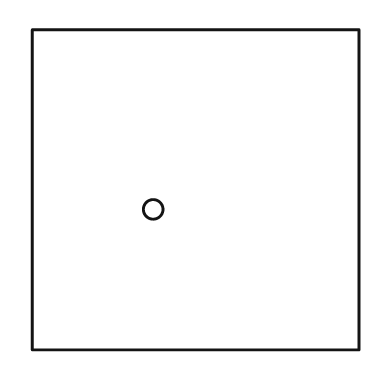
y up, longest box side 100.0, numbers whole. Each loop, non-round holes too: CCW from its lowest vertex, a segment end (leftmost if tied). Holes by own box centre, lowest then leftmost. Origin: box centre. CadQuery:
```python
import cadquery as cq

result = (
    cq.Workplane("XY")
    .moveTo(-50.0, -49.0)
    .lineTo(50.0, -49.0)
    .lineTo(50.0, 49.0)
    .lineTo(-50.0, 49.0)
    .close()
    .moveTo(-13.0, -6.0)
    .circle(3.0)
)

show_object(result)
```